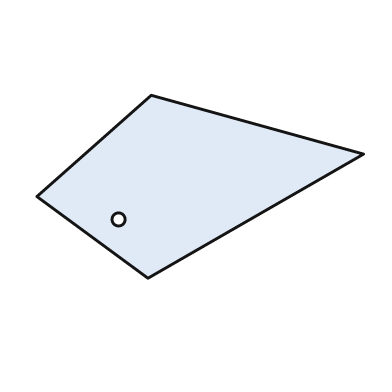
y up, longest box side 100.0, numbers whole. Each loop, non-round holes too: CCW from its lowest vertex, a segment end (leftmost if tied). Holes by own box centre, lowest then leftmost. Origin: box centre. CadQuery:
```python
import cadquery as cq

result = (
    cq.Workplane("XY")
    .moveTo(-16.0, -28.0)
    .lineTo(50.0, 10.0)
    .lineTo(-15.0, 28.0)
    .lineTo(-50.0, -3.0)
    .close()
    .moveTo(-25.0, -10.0)
    .circle(2.0)
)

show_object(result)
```